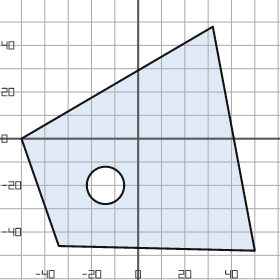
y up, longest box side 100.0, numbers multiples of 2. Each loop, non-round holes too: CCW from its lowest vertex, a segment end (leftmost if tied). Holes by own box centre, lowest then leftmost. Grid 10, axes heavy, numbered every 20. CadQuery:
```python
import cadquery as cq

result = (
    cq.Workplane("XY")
    .moveTo(50.0, -48.0)
    .lineTo(32.0, 48.0)
    .lineTo(-50.0, 0.0)
    .lineTo(-34.0, -46.0)
    .close()
    .moveTo(-14.0, -20.0)
    .circle(8.0)
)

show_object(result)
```